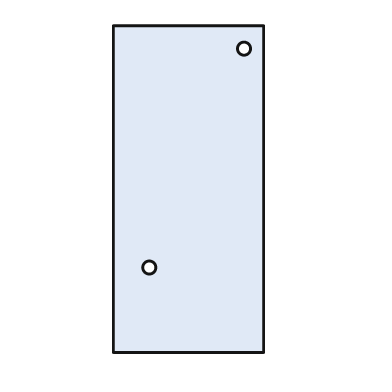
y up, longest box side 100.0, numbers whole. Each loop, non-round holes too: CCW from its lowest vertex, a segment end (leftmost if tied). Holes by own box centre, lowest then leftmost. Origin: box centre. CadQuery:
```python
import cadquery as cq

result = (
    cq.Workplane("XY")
    .moveTo(-23.0, -50.0)
    .lineTo(23.0, -50.0)
    .lineTo(23.0, 50.0)
    .lineTo(-23.0, 50.0)
    .close()
    .moveTo(-12.0, -24.0)
    .circle(2.0)
    .moveTo(17.0, 43.0)
    .circle(2.0)
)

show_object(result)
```